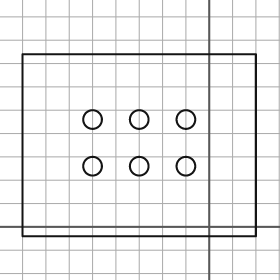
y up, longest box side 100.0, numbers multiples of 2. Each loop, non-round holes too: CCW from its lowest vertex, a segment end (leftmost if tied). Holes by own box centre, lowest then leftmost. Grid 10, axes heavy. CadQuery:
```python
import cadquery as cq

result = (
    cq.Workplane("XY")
    .moveTo(-80.0, -4.0)
    .lineTo(20.0, -4.0)
    .lineTo(20.0, 74.0)
    .lineTo(-80.0, 74.0)
    .close()
    .moveTo(-50.0, 26.0)
    .circle(4.0)
    .moveTo(-30.0, 26.0)
    .circle(4.0)
    .moveTo(-10.0, 26.0)
    .circle(4.0)
    .moveTo(-50.0, 46.0)
    .circle(4.0)
    .moveTo(-30.0, 46.0)
    .circle(4.0)
    .moveTo(-10.0, 46.0)
    .circle(4.0)
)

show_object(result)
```